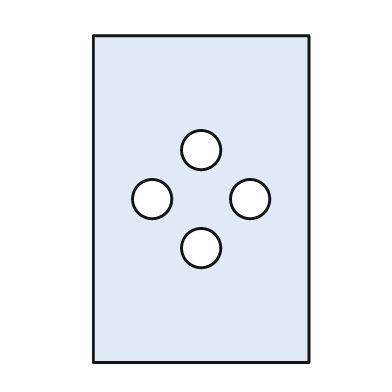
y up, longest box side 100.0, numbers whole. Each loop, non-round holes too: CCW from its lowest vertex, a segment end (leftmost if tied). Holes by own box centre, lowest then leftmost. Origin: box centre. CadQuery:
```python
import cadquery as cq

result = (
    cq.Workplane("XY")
    .moveTo(-33.0, -50.0)
    .lineTo(33.0, -50.0)
    .lineTo(33.0, 50.0)
    .lineTo(-33.0, 50.0)
    .close()
    .moveTo(0.0, -15.0)
    .circle(6.0)
    .moveTo(-15.0, 0.0)
    .circle(6.0)
    .moveTo(15.0, 0.0)
    .circle(6.0)
    .moveTo(0.0, 15.0)
    .circle(6.0)
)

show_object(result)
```